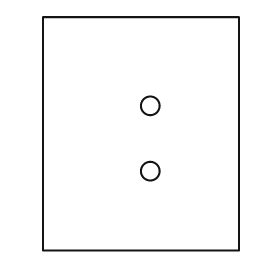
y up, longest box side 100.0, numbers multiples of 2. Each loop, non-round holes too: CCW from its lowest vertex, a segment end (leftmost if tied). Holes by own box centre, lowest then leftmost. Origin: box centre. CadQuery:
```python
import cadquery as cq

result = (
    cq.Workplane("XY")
    .moveTo(-42.0, -50.0)
    .lineTo(42.0, -50.0)
    .lineTo(42.0, 50.0)
    .lineTo(-42.0, 50.0)
    .close()
    .moveTo(4.0, -16.0)
    .circle(4.0)
    .moveTo(4.0, 12.0)
    .circle(4.0)
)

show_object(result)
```